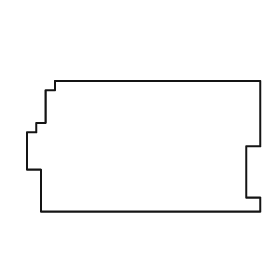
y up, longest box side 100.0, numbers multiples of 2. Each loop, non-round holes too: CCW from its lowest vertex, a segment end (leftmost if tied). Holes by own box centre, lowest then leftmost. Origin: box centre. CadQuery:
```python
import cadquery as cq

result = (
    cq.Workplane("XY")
    .moveTo(-44.0, -28.0)
    .lineTo(50.0, -28.0)
    .lineTo(50.0, -22.0)
    .lineTo(44.0, -22.0)
    .lineTo(44.0, 0.0)
    .lineTo(50.0, 0.0)
    .lineTo(50.0, 28.0)
    .lineTo(-38.0, 28.0)
    .lineTo(-38.0, 24.0)
    .lineTo(-42.0, 24.0)
    .lineTo(-42.0, 10.0)
    .lineTo(-46.0, 10.0)
    .lineTo(-46.0, 6.0)
    .lineTo(-50.0, 6.0)
    .lineTo(-50.0, -10.0)
    .lineTo(-44.0, -10.0)
    .close()
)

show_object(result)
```